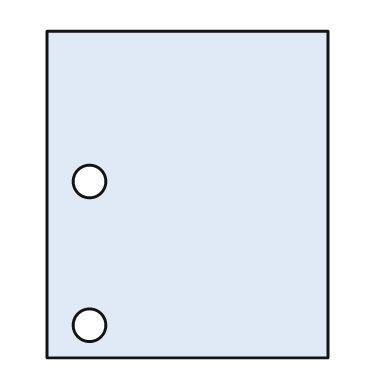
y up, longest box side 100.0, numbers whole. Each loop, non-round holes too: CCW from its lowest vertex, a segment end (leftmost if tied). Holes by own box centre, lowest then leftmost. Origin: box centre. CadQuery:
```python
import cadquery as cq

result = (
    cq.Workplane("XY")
    .moveTo(-43.0, -50.0)
    .lineTo(43.0, -50.0)
    .lineTo(43.0, 50.0)
    .lineTo(-43.0, 50.0)
    .close()
    .moveTo(-30.0, -40.0)
    .circle(5.0)
    .moveTo(-30.0, 4.0)
    .circle(5.0)
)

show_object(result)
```